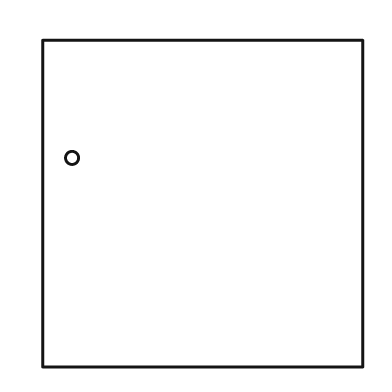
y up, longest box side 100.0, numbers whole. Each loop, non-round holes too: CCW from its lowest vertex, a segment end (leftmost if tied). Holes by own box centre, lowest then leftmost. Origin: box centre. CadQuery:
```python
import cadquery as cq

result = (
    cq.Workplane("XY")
    .moveTo(-49.0, -50.0)
    .lineTo(49.0, -50.0)
    .lineTo(49.0, 50.0)
    .lineTo(-49.0, 50.0)
    .close()
    .moveTo(-40.0, 14.0)
    .circle(2.0)
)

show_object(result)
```